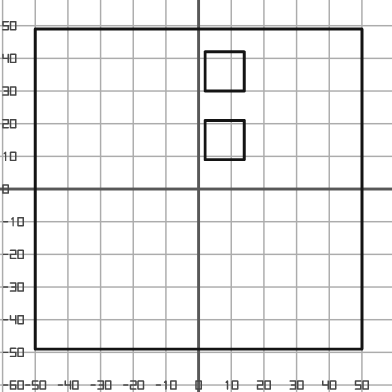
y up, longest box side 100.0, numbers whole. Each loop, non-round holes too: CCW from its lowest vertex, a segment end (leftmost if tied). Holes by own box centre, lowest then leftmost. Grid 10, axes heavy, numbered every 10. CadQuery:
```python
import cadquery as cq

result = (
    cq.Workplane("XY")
    .moveTo(-50.0, -49.0)
    .lineTo(50.0, -49.0)
    .lineTo(50.0, 49.0)
    .lineTo(-50.0, 49.0)
    .close()
    .moveTo(2.0, 9.0)
    .lineTo(14.0, 9.0)
    .lineTo(14.0, 21.0)
    .lineTo(2.0, 21.0)
    .close()
    .moveTo(2.0, 30.0)
    .lineTo(14.0, 30.0)
    .lineTo(14.0, 42.0)
    .lineTo(2.0, 42.0)
    .close()
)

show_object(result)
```